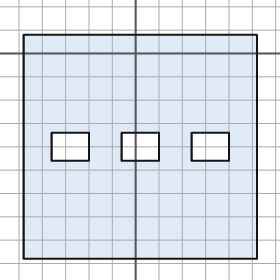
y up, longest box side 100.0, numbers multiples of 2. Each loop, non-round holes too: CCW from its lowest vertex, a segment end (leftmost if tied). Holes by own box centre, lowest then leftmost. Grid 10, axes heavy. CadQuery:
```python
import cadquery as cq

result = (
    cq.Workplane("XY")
    .moveTo(-48.0, -88.0)
    .lineTo(52.0, -88.0)
    .lineTo(52.0, 8.0)
    .lineTo(-48.0, 8.0)
    .close()
    .moveTo(-36.0, -46.0)
    .lineTo(-20.0, -46.0)
    .lineTo(-20.0, -34.0)
    .lineTo(-36.0, -34.0)
    .close()
    .moveTo(-6.0, -46.0)
    .lineTo(10.0, -46.0)
    .lineTo(10.0, -34.0)
    .lineTo(-6.0, -34.0)
    .close()
    .moveTo(24.0, -46.0)
    .lineTo(40.0, -46.0)
    .lineTo(40.0, -34.0)
    .lineTo(24.0, -34.0)
    .close()
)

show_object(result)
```